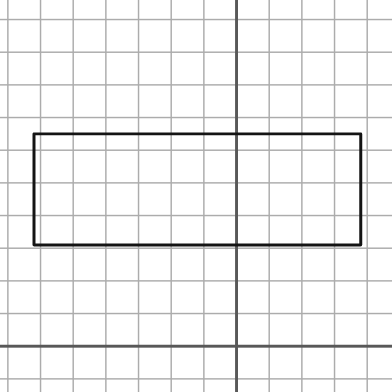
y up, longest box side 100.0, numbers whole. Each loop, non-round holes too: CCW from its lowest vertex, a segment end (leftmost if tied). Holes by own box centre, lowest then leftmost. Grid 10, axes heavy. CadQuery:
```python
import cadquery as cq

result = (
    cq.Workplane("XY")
    .moveTo(-62.0, 31.0)
    .lineTo(38.0, 31.0)
    .lineTo(38.0, 65.0)
    .lineTo(-62.0, 65.0)
    .close()
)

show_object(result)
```